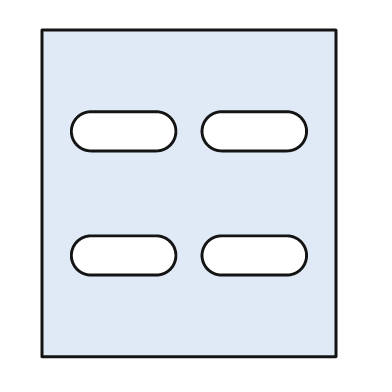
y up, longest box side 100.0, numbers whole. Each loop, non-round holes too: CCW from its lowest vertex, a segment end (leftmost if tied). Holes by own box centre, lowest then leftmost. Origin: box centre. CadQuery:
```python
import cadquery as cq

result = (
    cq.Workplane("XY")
    .moveTo(-45.0, -50.0)
    .lineTo(45.0, -50.0)
    .lineTo(45.0, 50.0)
    .lineTo(-45.0, 50.0)
    .close()
    .moveTo(-30.0, -25.0)
    .lineTo(-10.0, -25.0)
    .threePointArc((-4.0, -19.0), (-10.0, -13.0))
    .lineTo(-30.0, -13.0)
    .threePointArc((-36.0, -19.0), (-30.0, -25.0))
    .close()
    .moveTo(10.0, -25.0)
    .lineTo(30.0, -25.0)
    .threePointArc((36.0, -19.0), (30.0, -13.0))
    .lineTo(10.0, -13.0)
    .threePointArc((4.0, -19.0), (10.0, -25.0))
    .close()
    .moveTo(-30.0, 13.0)
    .lineTo(-10.0, 13.0)
    .threePointArc((-4.0, 19.0), (-10.0, 25.0))
    .lineTo(-30.0, 25.0)
    .threePointArc((-36.0, 19.0), (-30.0, 13.0))
    .close()
    .moveTo(10.0, 13.0)
    .lineTo(30.0, 13.0)
    .threePointArc((36.0, 19.0), (30.0, 25.0))
    .lineTo(10.0, 25.0)
    .threePointArc((4.0, 19.0), (10.0, 13.0))
    .close()
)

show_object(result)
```